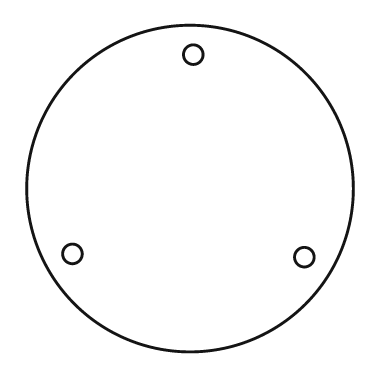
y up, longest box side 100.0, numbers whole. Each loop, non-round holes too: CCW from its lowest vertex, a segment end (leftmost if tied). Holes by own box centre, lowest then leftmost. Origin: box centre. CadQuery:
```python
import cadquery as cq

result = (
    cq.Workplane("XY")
    .moveTo(0.0, 0.0)
    .circle(50.0)
    .moveTo(35.0, -21.0)
    .circle(3.0)
    .moveTo(-36.0, -20.0)
    .circle(3.0)
    .moveTo(1.0, 41.0)
    .circle(3.0)
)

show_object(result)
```